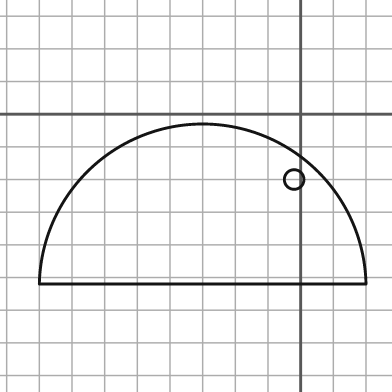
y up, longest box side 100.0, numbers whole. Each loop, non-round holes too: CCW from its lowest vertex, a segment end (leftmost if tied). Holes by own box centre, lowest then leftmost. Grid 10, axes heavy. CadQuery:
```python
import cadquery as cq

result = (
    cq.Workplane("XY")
    .moveTo(-80.0, -52.0)
    .lineTo(20.0, -52.0)
    .threePointArc((-30.0, -3.0), (-80.0, -52.0))
    .close()
    .moveTo(-2.0, -20.0)
    .circle(3.0)
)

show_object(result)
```